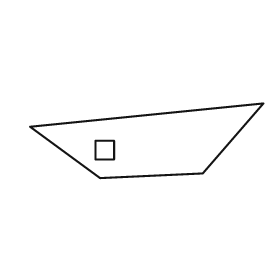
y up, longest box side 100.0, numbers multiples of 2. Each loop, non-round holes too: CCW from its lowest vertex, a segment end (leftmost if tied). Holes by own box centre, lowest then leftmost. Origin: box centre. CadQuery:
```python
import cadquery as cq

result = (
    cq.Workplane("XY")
    .moveTo(-20.0, -16.0)
    .lineTo(24.0, -14.0)
    .lineTo(50.0, 16.0)
    .lineTo(-50.0, 6.0)
    .close()
    .moveTo(-22.0, -8.0)
    .lineTo(-14.0, -8.0)
    .lineTo(-14.0, 0.0)
    .lineTo(-22.0, 0.0)
    .close()
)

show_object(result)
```